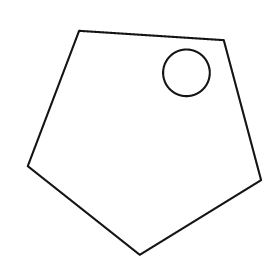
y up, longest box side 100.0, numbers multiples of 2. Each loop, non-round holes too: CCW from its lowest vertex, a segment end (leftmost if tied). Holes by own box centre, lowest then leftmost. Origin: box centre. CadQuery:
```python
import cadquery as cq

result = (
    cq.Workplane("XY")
    .moveTo(-2.0, -48.0)
    .lineTo(50.0, -16.0)
    .lineTo(34.0, 44.0)
    .lineTo(-28.0, 48.0)
    .lineTo(-50.0, -10.0)
    .close()
    .moveTo(18.0, 30.0)
    .circle(10.0)
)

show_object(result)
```